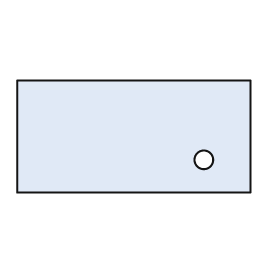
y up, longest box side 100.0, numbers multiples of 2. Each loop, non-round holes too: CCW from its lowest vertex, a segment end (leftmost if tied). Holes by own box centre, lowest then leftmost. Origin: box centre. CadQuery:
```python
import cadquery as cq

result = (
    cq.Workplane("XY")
    .moveTo(-50.0, -24.0)
    .lineTo(50.0, -24.0)
    .lineTo(50.0, 24.0)
    .lineTo(-50.0, 24.0)
    .close()
    .moveTo(30.0, -10.0)
    .circle(4.0)
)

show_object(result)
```